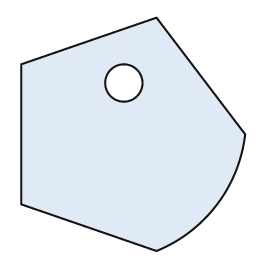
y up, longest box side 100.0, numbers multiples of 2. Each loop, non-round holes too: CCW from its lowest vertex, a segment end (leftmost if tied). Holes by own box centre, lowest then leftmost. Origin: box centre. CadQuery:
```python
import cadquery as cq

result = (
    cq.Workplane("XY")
    .moveTo(10.0, -50.0)
    .threePointArc((36.0, -30.0), (48.0, 0.0))
    .lineTo(10.0, 50.0)
    .lineTo(-48.0, 30.0)
    .lineTo(-48.0, -30.0)
    .close()
    .moveTo(-4.0, 22.0)
    .circle(8.0)
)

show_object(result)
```